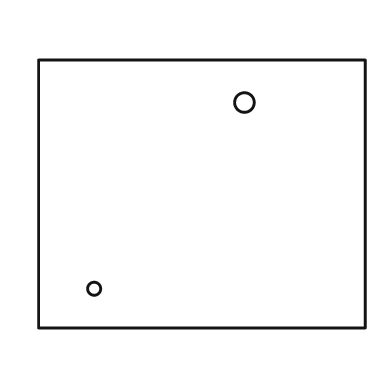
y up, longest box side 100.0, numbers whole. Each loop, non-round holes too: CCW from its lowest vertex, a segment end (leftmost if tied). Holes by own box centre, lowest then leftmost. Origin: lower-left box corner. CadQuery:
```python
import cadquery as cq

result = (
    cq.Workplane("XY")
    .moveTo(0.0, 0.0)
    .lineTo(100.0, 0.0)
    .lineTo(100.0, 82.0)
    .lineTo(0.0, 82.0)
    .close()
    .moveTo(17.0, 12.0)
    .circle(2.0)
    .moveTo(63.0, 69.0)
    .circle(3.0)
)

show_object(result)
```